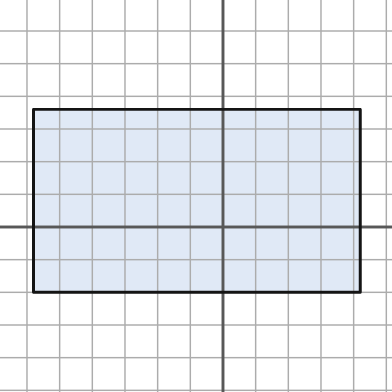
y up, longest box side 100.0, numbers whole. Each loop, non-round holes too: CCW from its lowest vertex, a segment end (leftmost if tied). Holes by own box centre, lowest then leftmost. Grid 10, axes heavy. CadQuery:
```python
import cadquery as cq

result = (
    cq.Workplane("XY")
    .moveTo(-58.0, -20.0)
    .lineTo(42.0, -20.0)
    .lineTo(42.0, 36.0)
    .lineTo(-58.0, 36.0)
    .close()
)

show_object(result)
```